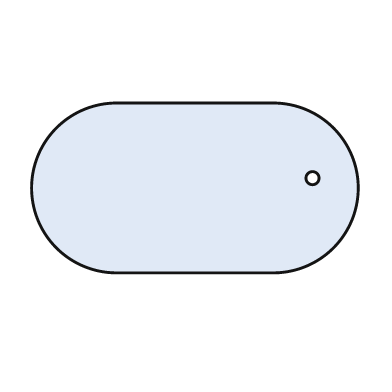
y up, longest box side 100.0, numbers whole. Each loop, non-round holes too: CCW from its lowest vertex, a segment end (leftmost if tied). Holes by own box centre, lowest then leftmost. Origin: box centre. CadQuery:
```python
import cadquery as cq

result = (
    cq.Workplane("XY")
    .moveTo(-24.0, -26.0)
    .lineTo(24.0, -26.0)
    .threePointArc((50.0, 0.0), (24.0, 26.0))
    .lineTo(-24.0, 26.0)
    .threePointArc((-50.0, 0.0), (-24.0, -26.0))
    .close()
    .moveTo(36.0, 3.0)
    .circle(2.0)
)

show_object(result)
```